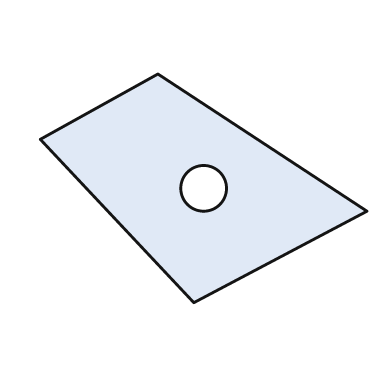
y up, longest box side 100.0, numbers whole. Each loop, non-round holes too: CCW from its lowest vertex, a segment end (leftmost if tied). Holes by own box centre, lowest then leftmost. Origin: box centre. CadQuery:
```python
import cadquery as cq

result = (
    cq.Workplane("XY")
    .moveTo(-3.0, -35.0)
    .lineTo(50.0, -7.0)
    .lineTo(-14.0, 35.0)
    .lineTo(-50.0, 15.0)
    .close()
    .moveTo(0.0, 0.0)
    .circle(7.0)
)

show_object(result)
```